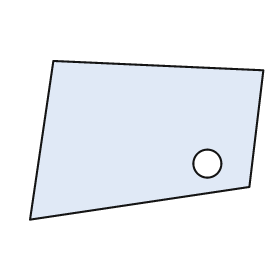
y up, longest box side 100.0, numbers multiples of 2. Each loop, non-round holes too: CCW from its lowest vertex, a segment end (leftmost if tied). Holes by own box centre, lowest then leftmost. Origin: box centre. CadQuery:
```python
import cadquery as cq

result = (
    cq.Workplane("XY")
    .moveTo(-50.0, -34.0)
    .lineTo(44.0, -20.0)
    .lineTo(50.0, 30.0)
    .lineTo(-40.0, 34.0)
    .close()
    .moveTo(26.0, -10.0)
    .circle(6.0)
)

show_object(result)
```